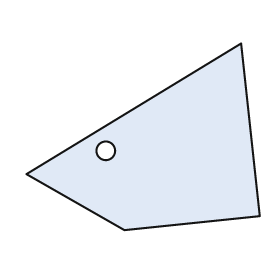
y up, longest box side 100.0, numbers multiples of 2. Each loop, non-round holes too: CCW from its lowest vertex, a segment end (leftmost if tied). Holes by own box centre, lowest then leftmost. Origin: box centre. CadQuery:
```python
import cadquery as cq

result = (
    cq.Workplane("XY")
    .moveTo(-8.0, -40.0)
    .lineTo(50.0, -34.0)
    .lineTo(42.0, 40.0)
    .lineTo(-50.0, -16.0)
    .close()
    .moveTo(-16.0, -6.0)
    .circle(4.0)
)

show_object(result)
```